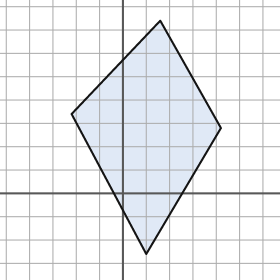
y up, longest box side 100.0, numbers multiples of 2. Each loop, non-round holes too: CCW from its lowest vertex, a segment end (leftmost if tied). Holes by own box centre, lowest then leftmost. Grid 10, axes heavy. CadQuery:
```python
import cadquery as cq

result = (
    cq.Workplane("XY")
    .moveTo(10.0, -26.0)
    .lineTo(42.0, 28.0)
    .lineTo(16.0, 74.0)
    .lineTo(-22.0, 34.0)
    .close()
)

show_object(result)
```